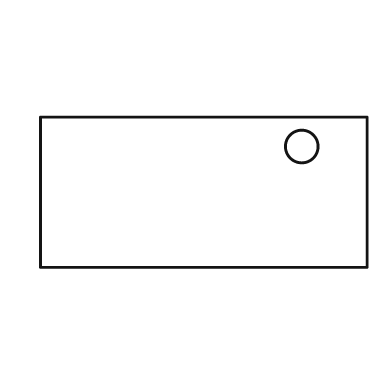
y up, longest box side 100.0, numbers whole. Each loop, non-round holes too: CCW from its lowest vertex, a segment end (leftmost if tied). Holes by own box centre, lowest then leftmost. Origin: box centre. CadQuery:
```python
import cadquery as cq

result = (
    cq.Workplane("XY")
    .moveTo(-50.0, -23.0)
    .lineTo(50.0, -23.0)
    .lineTo(50.0, 23.0)
    .lineTo(-50.0, 23.0)
    .close()
    .moveTo(30.0, 14.0)
    .circle(5.0)
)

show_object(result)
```